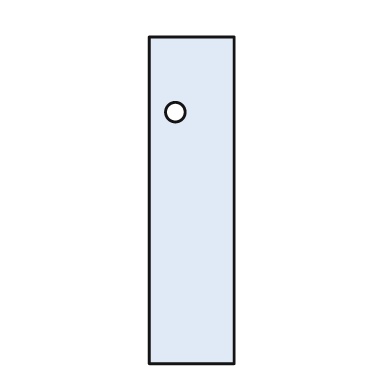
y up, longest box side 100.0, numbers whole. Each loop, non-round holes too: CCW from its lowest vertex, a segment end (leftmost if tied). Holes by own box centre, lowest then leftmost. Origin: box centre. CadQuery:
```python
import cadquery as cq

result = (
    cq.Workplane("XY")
    .moveTo(-13.0, -50.0)
    .lineTo(13.0, -50.0)
    .lineTo(13.0, 50.0)
    .lineTo(-13.0, 50.0)
    .close()
    .moveTo(-5.0, 27.0)
    .circle(3.0)
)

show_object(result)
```